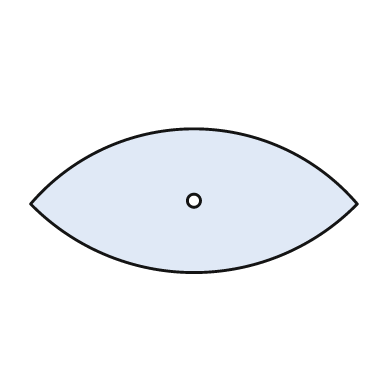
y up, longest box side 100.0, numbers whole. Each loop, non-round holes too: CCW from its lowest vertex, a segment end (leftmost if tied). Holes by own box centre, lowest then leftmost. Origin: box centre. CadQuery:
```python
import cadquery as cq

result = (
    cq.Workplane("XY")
    .moveTo(-50.0, -1.0)
    .threePointArc((0.0, -22.0), (50.0, -1.0))
    .threePointArc((0.0, 22.0), (-50.0, -1.0))
    .close()
    .moveTo(0.0, 0.0)
    .circle(2.0)
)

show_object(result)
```